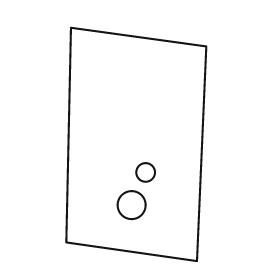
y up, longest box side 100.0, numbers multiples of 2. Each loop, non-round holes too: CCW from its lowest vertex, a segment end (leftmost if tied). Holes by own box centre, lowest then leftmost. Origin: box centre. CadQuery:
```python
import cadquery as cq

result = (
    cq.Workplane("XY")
    .moveTo(26.0, -50.0)
    .lineTo(30.0, 42.0)
    .lineTo(-28.0, 50.0)
    .lineTo(-30.0, -42.0)
    .close()
    .moveTo(-2.0, -26.0)
    .circle(6.0)
    .moveTo(4.0, -12.0)
    .circle(4.0)
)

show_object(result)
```